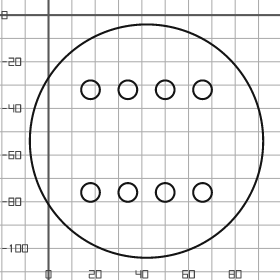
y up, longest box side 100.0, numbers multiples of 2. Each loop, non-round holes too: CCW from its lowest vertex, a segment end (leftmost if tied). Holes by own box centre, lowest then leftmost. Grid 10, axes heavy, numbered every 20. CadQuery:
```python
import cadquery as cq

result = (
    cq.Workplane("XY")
    .moveTo(42.0, -54.0)
    .circle(50.0)
    .moveTo(18.0, -76.0)
    .circle(4.0)
    .moveTo(34.0, -76.0)
    .circle(4.0)
    .moveTo(50.0, -76.0)
    .circle(4.0)
    .moveTo(66.0, -76.0)
    .circle(4.0)
    .moveTo(18.0, -32.0)
    .circle(4.0)
    .moveTo(34.0, -32.0)
    .circle(4.0)
    .moveTo(50.0, -32.0)
    .circle(4.0)
    .moveTo(66.0, -32.0)
    .circle(4.0)
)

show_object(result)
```